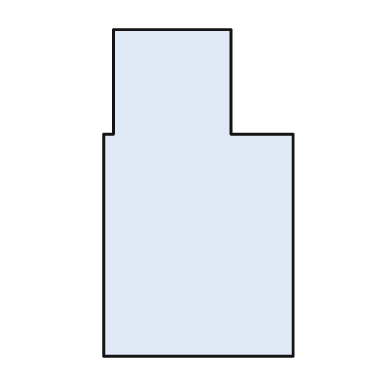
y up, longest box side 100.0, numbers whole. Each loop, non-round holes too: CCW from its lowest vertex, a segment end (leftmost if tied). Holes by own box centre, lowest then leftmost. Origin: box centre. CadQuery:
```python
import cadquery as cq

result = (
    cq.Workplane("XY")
    .moveTo(-29.0, -50.0)
    .lineTo(29.0, -50.0)
    .lineTo(29.0, 18.0)
    .lineTo(10.0, 18.0)
    .lineTo(10.0, 50.0)
    .lineTo(-26.0, 50.0)
    .lineTo(-26.0, 18.0)
    .lineTo(-29.0, 18.0)
    .close()
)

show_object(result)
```